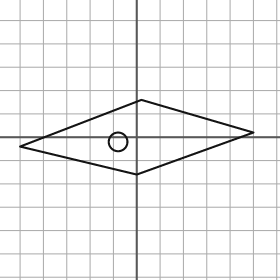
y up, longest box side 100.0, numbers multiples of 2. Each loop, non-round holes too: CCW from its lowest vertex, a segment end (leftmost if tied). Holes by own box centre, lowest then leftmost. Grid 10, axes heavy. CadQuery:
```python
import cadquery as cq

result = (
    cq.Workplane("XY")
    .moveTo(0.0, -16.0)
    .lineTo(50.0, 2.0)
    .lineTo(2.0, 16.0)
    .lineTo(-50.0, -4.0)
    .close()
    .moveTo(-8.0, -2.0)
    .circle(4.0)
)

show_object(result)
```